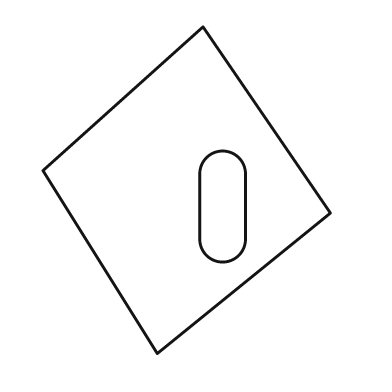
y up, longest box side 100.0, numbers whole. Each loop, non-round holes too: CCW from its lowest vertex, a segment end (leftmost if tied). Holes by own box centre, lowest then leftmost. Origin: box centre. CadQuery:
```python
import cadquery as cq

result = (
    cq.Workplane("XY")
    .moveTo(-9.0, -50.0)
    .lineTo(44.0, -7.0)
    .lineTo(5.0, 50.0)
    .lineTo(-44.0, 6.0)
    .close()
    .moveTo(4.0, -15.0)
    .threePointArc((11.0, -22.0), (18.0, -15.0))
    .lineTo(18.0, 5.0)
    .threePointArc((11.0, 12.0), (4.0, 5.0))
    .close()
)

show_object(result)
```